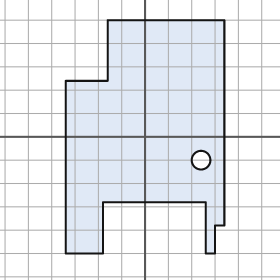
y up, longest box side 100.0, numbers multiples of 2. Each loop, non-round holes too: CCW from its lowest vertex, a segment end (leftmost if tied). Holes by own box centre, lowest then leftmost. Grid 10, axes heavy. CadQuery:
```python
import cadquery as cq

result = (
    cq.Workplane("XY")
    .moveTo(-34.0, -50.0)
    .lineTo(-18.0, -50.0)
    .lineTo(-18.0, -28.0)
    .lineTo(26.0, -28.0)
    .lineTo(26.0, -50.0)
    .lineTo(30.0, -50.0)
    .lineTo(30.0, -38.0)
    .lineTo(34.0, -38.0)
    .lineTo(34.0, 50.0)
    .lineTo(-16.0, 50.0)
    .lineTo(-16.0, 24.0)
    .lineTo(-34.0, 24.0)
    .close()
    .moveTo(24.0, -10.0)
    .circle(4.0)
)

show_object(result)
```